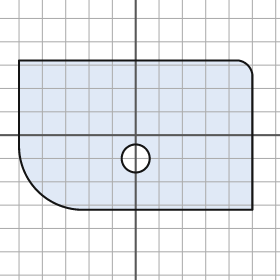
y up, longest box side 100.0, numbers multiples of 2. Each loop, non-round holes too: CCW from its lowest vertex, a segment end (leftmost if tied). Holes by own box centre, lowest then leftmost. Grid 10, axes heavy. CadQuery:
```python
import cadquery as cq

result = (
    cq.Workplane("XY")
    .moveTo(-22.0, -32.0)
    .lineTo(50.0, -32.0)
    .lineTo(50.0, 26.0)
    .threePointArc((48.0, 30.0), (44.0, 32.0))
    .lineTo(-50.0, 32.0)
    .lineTo(-50.0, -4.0)
    .threePointArc((-42.0, -24.0), (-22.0, -32.0))
    .close()
    .moveTo(0.0, -10.0)
    .circle(6.0)
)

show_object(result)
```